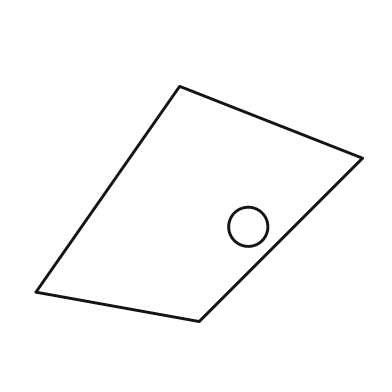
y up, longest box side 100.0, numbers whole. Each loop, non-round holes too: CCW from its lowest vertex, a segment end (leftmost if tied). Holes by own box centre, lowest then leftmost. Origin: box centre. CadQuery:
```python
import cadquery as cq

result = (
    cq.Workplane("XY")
    .moveTo(0.0, -36.0)
    .lineTo(50.0, 14.0)
    .lineTo(-6.0, 36.0)
    .lineTo(-50.0, -27.0)
    .close()
    .moveTo(15.0, -7.0)
    .circle(6.0)
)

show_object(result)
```